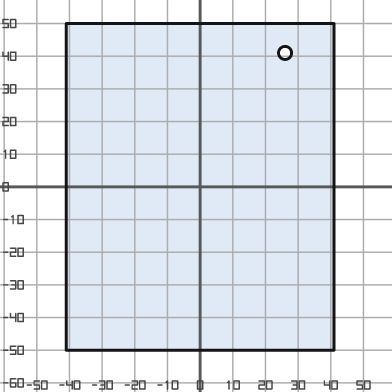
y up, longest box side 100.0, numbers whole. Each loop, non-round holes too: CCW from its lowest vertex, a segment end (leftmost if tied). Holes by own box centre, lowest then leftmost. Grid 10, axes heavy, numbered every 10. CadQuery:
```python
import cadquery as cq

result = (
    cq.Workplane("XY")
    .moveTo(-41.0, -50.0)
    .lineTo(41.0, -50.0)
    .lineTo(41.0, 50.0)
    .lineTo(-41.0, 50.0)
    .close()
    .moveTo(26.0, 41.0)
    .circle(2.0)
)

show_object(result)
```